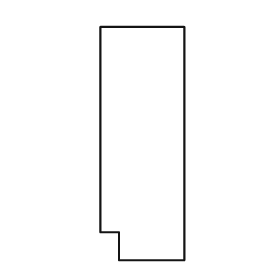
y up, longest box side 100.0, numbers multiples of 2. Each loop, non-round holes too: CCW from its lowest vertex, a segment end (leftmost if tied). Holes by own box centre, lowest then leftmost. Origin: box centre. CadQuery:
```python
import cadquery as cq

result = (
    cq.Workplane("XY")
    .moveTo(-10.0, -50.0)
    .lineTo(18.0, -50.0)
    .lineTo(18.0, 50.0)
    .lineTo(-18.0, 50.0)
    .lineTo(-18.0, -38.0)
    .lineTo(-10.0, -38.0)
    .close()
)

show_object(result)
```